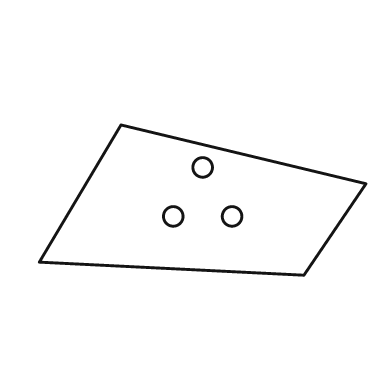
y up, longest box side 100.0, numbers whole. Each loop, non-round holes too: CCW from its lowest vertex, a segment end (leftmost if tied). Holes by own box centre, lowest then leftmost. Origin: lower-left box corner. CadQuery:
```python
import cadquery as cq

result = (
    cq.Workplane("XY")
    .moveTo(81.0, 0.0)
    .lineTo(100.0, 28.0)
    .lineTo(25.0, 46.0)
    .lineTo(0.0, 4.0)
    .close()
    .moveTo(41.0, 18.0)
    .circle(3.0)
    .moveTo(59.0, 18.0)
    .circle(3.0)
    .moveTo(50.0, 33.0)
    .circle(3.0)
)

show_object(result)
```